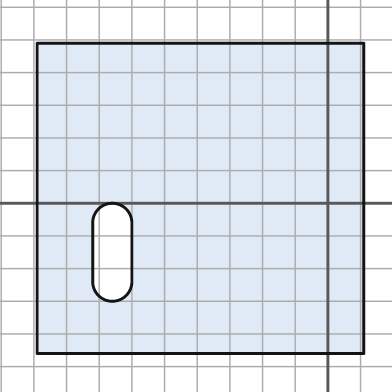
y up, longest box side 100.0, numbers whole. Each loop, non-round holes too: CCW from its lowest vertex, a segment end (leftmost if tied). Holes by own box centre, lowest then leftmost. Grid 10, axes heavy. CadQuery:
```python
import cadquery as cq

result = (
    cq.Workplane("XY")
    .moveTo(-89.0, -46.0)
    .lineTo(11.0, -46.0)
    .lineTo(11.0, 49.0)
    .lineTo(-89.0, 49.0)
    .close()
    .moveTo(-72.0, -24.0)
    .threePointArc((-66.0, -30.0), (-60.0, -24.0))
    .lineTo(-60.0, -6.0)
    .threePointArc((-66.0, 0.0), (-72.0, -6.0))
    .close()
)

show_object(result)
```